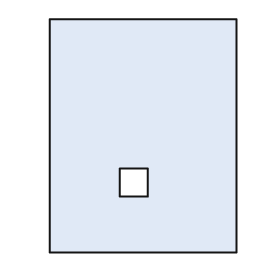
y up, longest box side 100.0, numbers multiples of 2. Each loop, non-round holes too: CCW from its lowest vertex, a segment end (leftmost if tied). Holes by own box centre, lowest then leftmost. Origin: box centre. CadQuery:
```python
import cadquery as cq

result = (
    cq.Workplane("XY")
    .moveTo(-40.0, -50.0)
    .lineTo(40.0, -50.0)
    .lineTo(40.0, 50.0)
    .lineTo(-40.0, 50.0)
    .close()
    .moveTo(-10.0, -26.0)
    .lineTo(2.0, -26.0)
    .lineTo(2.0, -14.0)
    .lineTo(-10.0, -14.0)
    .close()
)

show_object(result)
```